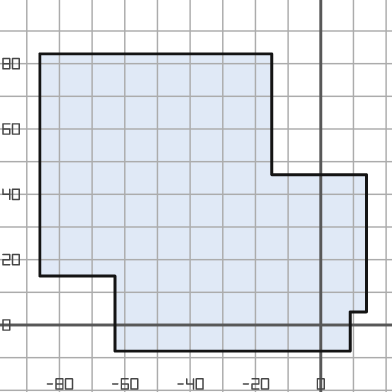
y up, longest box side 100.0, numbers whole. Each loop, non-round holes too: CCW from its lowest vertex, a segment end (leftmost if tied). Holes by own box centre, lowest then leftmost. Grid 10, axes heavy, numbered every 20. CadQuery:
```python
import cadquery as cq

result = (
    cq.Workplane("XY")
    .moveTo(-63.0, -8.0)
    .lineTo(9.0, -8.0)
    .lineTo(9.0, 4.0)
    .lineTo(14.0, 4.0)
    .lineTo(14.0, 46.0)
    .lineTo(-15.0, 46.0)
    .lineTo(-15.0, 83.0)
    .lineTo(-86.0, 83.0)
    .lineTo(-86.0, 15.0)
    .lineTo(-63.0, 15.0)
    .close()
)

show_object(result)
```